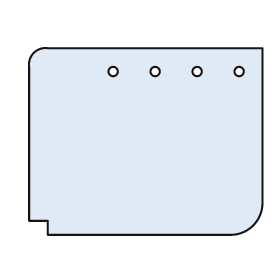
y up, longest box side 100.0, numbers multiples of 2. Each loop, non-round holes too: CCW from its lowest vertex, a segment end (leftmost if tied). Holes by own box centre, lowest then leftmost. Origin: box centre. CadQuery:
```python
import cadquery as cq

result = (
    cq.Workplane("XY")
    .moveTo(-42.0, -40.0)
    .lineTo(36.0, -40.0)
    .threePointArc((46.0, -36.0), (50.0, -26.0))
    .lineTo(50.0, 40.0)
    .lineTo(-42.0, 40.0)
    .threePointArc((-48.0, 38.0), (-50.0, 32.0))
    .lineTo(-50.0, -34.0)
    .lineTo(-42.0, -34.0)
    .close()
    .moveTo(-14.0, 30.0)
    .circle(2.0)
    .moveTo(4.0, 30.0)
    .circle(2.0)
    .moveTo(22.0, 30.0)
    .circle(2.0)
    .moveTo(40.0, 30.0)
    .circle(2.0)
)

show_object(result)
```